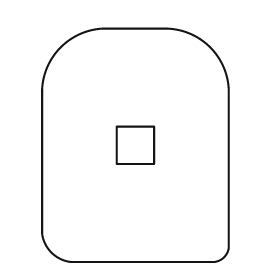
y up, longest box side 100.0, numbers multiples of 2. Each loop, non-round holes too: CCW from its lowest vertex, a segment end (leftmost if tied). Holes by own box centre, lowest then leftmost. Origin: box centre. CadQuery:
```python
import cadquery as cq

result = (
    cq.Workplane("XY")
    .moveTo(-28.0, -50.0)
    .lineTo(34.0, -50.0)
    .threePointArc((38.0, -48.0), (40.0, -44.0))
    .lineTo(40.0, 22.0)
    .threePointArc((32.0, 42.0), (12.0, 50.0))
    .lineTo(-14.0, 50.0)
    .threePointArc((-32.0, 42.0), (-40.0, 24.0))
    .lineTo(-40.0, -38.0)
    .threePointArc((-36.0, -46.0), (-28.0, -50.0))
    .close()
    .moveTo(-8.0, -8.0)
    .lineTo(8.0, -8.0)
    .lineTo(8.0, 8.0)
    .lineTo(-8.0, 8.0)
    .close()
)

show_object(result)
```